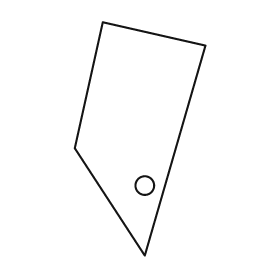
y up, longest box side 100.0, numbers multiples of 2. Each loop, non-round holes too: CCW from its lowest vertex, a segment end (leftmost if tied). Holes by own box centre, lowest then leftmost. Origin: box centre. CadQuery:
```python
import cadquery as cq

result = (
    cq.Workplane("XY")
    .moveTo(2.0, -50.0)
    .lineTo(28.0, 40.0)
    .lineTo(-16.0, 50.0)
    .lineTo(-28.0, -4.0)
    .close()
    .moveTo(2.0, -20.0)
    .circle(4.0)
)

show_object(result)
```